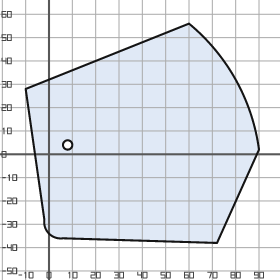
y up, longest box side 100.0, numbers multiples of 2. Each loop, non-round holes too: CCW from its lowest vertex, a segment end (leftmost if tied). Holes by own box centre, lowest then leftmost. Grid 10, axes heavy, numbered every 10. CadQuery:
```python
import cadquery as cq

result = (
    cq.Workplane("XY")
    .moveTo(72.0, -38.0)
    .lineTo(90.0, 2.0)
    .threePointArc((80.0, 32.0), (60.0, 56.0))
    .lineTo(-10.0, 28.0)
    .lineTo(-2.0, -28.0)
    .threePointArc((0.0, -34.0), (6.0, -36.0))
    .close()
    .moveTo(8.0, 4.0)
    .circle(2.0)
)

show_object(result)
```